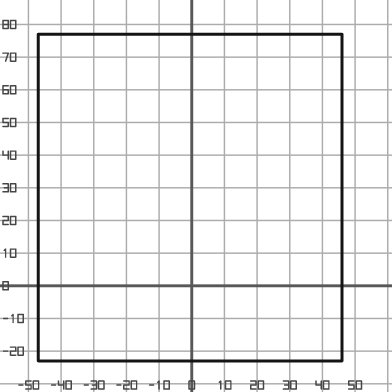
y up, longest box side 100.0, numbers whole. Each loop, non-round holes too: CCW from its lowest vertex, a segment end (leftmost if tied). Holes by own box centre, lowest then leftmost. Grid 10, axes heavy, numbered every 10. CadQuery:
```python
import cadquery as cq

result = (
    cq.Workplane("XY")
    .moveTo(-47.0, -23.0)
    .lineTo(46.0, -23.0)
    .lineTo(46.0, 77.0)
    .lineTo(-47.0, 77.0)
    .close()
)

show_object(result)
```